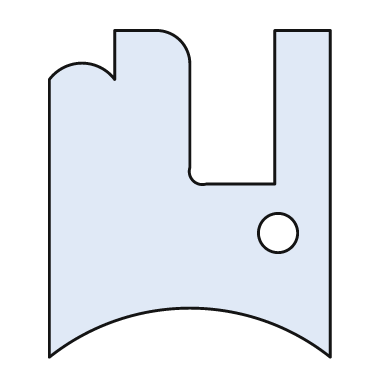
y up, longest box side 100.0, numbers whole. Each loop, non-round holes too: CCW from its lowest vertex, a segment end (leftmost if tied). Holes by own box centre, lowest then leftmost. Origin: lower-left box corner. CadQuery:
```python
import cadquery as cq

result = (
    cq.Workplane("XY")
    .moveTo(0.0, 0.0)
    .threePointArc((43.0, 15.0), (86.0, 0.0))
    .lineTo(86.0, 100.0)
    .lineTo(69.0, 100.0)
    .lineTo(69.0, 53.0)
    .lineTo(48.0, 53.0)
    .threePointArc((44.0, 54.0), (43.0, 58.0))
    .lineTo(43.0, 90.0)
    .threePointArc((40.0, 97.0), (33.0, 100.0))
    .lineTo(20.0, 100.0)
    .lineTo(20.0, 85.0)
    .threePointArc((10.0, 90.0), (0.0, 85.0))
    .close()
    .moveTo(70.0, 38.0)
    .circle(6.0)
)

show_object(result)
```